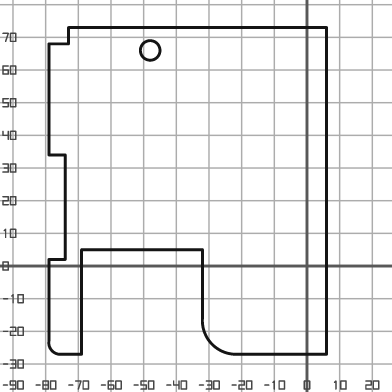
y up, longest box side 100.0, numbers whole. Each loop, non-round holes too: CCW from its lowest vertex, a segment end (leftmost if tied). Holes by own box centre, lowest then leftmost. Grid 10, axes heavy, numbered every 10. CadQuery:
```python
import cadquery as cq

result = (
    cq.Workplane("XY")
    .moveTo(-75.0, -27.0)
    .lineTo(-69.0, -27.0)
    .lineTo(-69.0, 5.0)
    .lineTo(-32.0, 5.0)
    .lineTo(-32.0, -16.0)
    .threePointArc((-29.0, -24.0), (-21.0, -27.0))
    .lineTo(6.0, -27.0)
    .lineTo(6.0, 73.0)
    .lineTo(-73.0, 73.0)
    .lineTo(-73.0, 68.0)
    .lineTo(-79.0, 68.0)
    .lineTo(-79.0, 34.0)
    .lineTo(-74.0, 34.0)
    .lineTo(-74.0, 2.0)
    .lineTo(-79.0, 2.0)
    .lineTo(-79.0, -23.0)
    .threePointArc((-78.0, -26.0), (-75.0, -27.0))
    .close()
    .moveTo(-48.0, 66.0)
    .circle(3.0)
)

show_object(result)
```